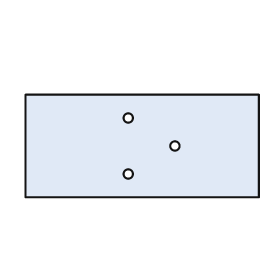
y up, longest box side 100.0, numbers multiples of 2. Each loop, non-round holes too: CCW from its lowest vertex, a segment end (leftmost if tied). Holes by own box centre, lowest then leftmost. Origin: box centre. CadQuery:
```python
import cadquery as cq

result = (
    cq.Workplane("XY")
    .moveTo(-50.0, -22.0)
    .lineTo(50.0, -22.0)
    .lineTo(50.0, 22.0)
    .lineTo(-50.0, 22.0)
    .close()
    .moveTo(-6.0, -12.0)
    .circle(2.0)
    .moveTo(14.0, 0.0)
    .circle(2.0)
    .moveTo(-6.0, 12.0)
    .circle(2.0)
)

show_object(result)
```